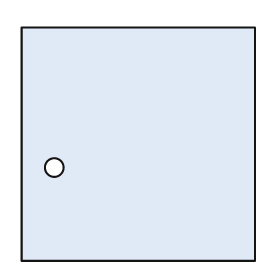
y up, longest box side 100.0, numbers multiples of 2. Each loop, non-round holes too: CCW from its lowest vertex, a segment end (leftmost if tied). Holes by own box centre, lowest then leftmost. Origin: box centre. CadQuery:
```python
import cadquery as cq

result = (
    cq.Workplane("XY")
    .moveTo(-50.0, -50.0)
    .lineTo(50.0, -50.0)
    .lineTo(50.0, 50.0)
    .lineTo(-50.0, 50.0)
    .close()
    .moveTo(-36.0, -10.0)
    .circle(4.0)
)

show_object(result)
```